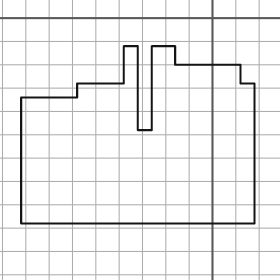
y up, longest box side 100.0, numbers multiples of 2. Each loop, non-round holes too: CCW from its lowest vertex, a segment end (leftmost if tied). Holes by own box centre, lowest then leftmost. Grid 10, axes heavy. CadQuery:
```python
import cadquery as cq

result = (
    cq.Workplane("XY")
    .moveTo(-82.0, -88.0)
    .lineTo(18.0, -88.0)
    .lineTo(18.0, -28.0)
    .lineTo(12.0, -28.0)
    .lineTo(12.0, -20.0)
    .lineTo(-16.0, -20.0)
    .lineTo(-16.0, -12.0)
    .lineTo(-26.0, -12.0)
    .lineTo(-26.0, -48.0)
    .lineTo(-32.0, -48.0)
    .lineTo(-32.0, -12.0)
    .lineTo(-38.0, -12.0)
    .lineTo(-38.0, -28.0)
    .lineTo(-58.0, -28.0)
    .lineTo(-58.0, -34.0)
    .lineTo(-82.0, -34.0)
    .close()
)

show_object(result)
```